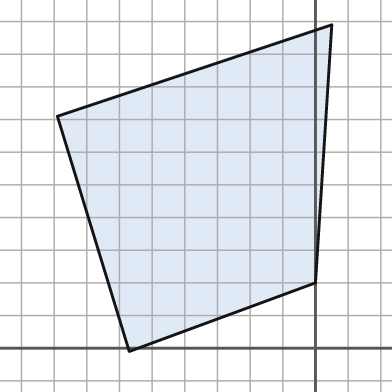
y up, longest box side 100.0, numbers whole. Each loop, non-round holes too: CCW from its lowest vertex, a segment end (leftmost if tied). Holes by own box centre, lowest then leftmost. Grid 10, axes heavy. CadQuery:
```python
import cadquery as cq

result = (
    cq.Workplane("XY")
    .moveTo(-57.0, -1.0)
    .lineTo(0.0, 20.0)
    .lineTo(5.0, 99.0)
    .lineTo(-79.0, 71.0)
    .close()
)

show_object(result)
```